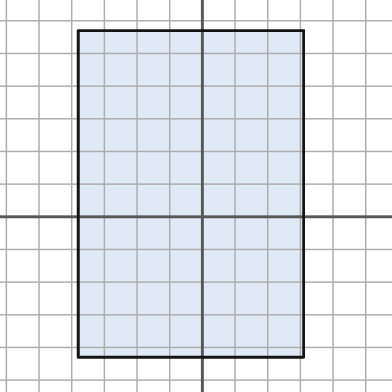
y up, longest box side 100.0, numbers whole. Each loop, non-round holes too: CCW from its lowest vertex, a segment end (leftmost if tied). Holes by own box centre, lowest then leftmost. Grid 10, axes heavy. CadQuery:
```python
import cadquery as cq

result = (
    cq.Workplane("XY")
    .moveTo(-38.0, -43.0)
    .lineTo(31.0, -43.0)
    .lineTo(31.0, 57.0)
    .lineTo(-38.0, 57.0)
    .close()
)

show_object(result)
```